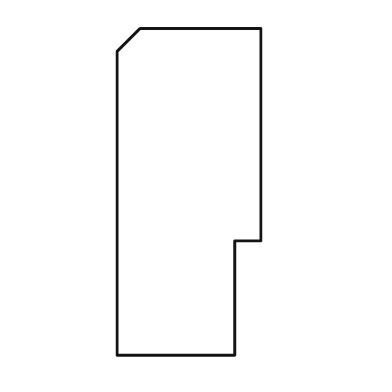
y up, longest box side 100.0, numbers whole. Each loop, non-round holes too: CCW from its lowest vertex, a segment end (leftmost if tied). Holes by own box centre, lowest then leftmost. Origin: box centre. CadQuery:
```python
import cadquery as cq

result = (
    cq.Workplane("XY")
    .moveTo(-22.0, -50.0)
    .lineTo(14.0, -50.0)
    .lineTo(14.0, -15.0)
    .lineTo(22.0, -15.0)
    .lineTo(22.0, 50.0)
    .lineTo(-15.0, 50.0)
    .lineTo(-22.0, 43.0)
    .close()
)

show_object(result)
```